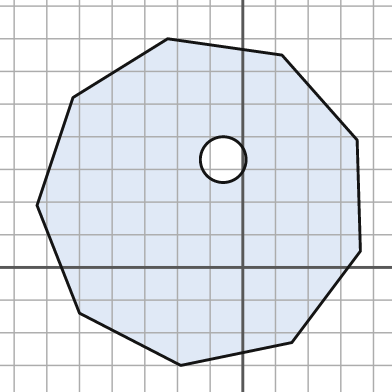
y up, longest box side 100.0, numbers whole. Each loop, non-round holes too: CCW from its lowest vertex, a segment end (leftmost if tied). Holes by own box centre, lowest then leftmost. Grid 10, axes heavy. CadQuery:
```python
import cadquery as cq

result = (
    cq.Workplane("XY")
    .moveTo(-19.0, -30.0)
    .lineTo(15.0, -23.0)
    .lineTo(36.0, 5.0)
    .lineTo(35.0, 39.0)
    .lineTo(12.0, 65.0)
    .lineTo(-23.0, 70.0)
    .lineTo(-52.0, 52.0)
    .lineTo(-63.0, 19.0)
    .lineTo(-50.0, -14.0)
    .close()
    .moveTo(-6.0, 33.0)
    .circle(7.0)
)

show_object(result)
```